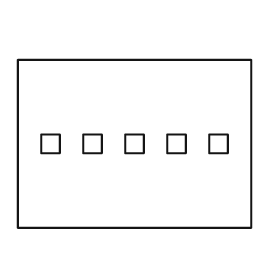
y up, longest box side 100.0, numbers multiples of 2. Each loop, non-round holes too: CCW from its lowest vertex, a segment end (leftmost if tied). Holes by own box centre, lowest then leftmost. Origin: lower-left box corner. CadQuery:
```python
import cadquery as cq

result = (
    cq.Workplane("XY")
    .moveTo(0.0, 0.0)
    .lineTo(100.0, 0.0)
    .lineTo(100.0, 72.0)
    .lineTo(0.0, 72.0)
    .close()
    .moveTo(10.0, 32.0)
    .lineTo(18.0, 32.0)
    .lineTo(18.0, 40.0)
    .lineTo(10.0, 40.0)
    .close()
    .moveTo(28.0, 32.0)
    .lineTo(36.0, 32.0)
    .lineTo(36.0, 40.0)
    .lineTo(28.0, 40.0)
    .close()
    .moveTo(46.0, 32.0)
    .lineTo(54.0, 32.0)
    .lineTo(54.0, 40.0)
    .lineTo(46.0, 40.0)
    .close()
    .moveTo(64.0, 32.0)
    .lineTo(72.0, 32.0)
    .lineTo(72.0, 40.0)
    .lineTo(64.0, 40.0)
    .close()
    .moveTo(82.0, 32.0)
    .lineTo(90.0, 32.0)
    .lineTo(90.0, 40.0)
    .lineTo(82.0, 40.0)
    .close()
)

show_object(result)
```